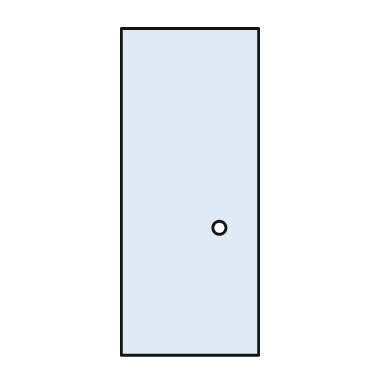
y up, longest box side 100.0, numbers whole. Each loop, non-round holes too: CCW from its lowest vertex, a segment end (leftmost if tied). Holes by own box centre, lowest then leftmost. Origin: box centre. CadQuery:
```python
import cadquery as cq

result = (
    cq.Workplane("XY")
    .moveTo(-21.0, -50.0)
    .lineTo(21.0, -50.0)
    .lineTo(21.0, 50.0)
    .lineTo(-21.0, 50.0)
    .close()
    .moveTo(9.0, -11.0)
    .circle(2.0)
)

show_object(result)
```